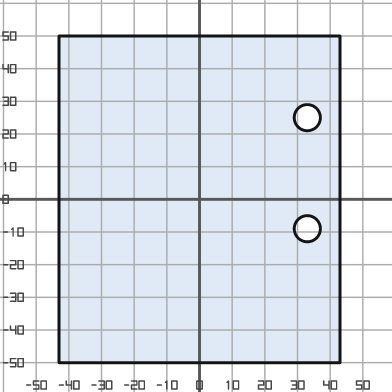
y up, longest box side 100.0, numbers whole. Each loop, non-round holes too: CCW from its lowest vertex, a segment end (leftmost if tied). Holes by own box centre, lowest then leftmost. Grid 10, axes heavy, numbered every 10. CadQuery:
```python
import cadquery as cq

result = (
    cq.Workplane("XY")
    .moveTo(-43.0, -50.0)
    .lineTo(43.0, -50.0)
    .lineTo(43.0, 50.0)
    .lineTo(-43.0, 50.0)
    .close()
    .moveTo(33.0, -9.0)
    .circle(4.0)
    .moveTo(33.0, 25.0)
    .circle(4.0)
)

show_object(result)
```